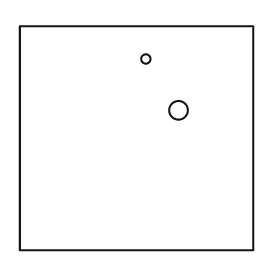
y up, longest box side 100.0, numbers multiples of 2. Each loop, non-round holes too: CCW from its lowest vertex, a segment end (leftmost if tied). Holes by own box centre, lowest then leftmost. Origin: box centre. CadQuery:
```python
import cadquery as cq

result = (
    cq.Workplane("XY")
    .moveTo(-50.0, -48.0)
    .lineTo(50.0, -48.0)
    .lineTo(50.0, 48.0)
    .lineTo(-50.0, 48.0)
    .close()
    .moveTo(18.0, 12.0)
    .circle(4.0)
    .moveTo(4.0, 34.0)
    .circle(2.0)
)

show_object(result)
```